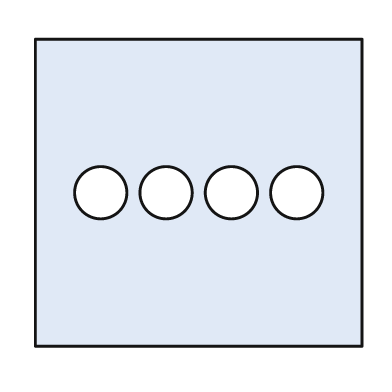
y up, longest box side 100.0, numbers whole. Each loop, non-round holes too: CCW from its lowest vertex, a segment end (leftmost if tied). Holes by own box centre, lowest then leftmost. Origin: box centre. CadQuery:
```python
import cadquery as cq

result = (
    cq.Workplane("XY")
    .moveTo(-50.0, -47.0)
    .lineTo(50.0, -47.0)
    .lineTo(50.0, 47.0)
    .lineTo(-50.0, 47.0)
    .close()
    .moveTo(-30.0, 0.0)
    .circle(8.0)
    .moveTo(-10.0, 0.0)
    .circle(8.0)
    .moveTo(10.0, 0.0)
    .circle(8.0)
    .moveTo(30.0, 0.0)
    .circle(8.0)
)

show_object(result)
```